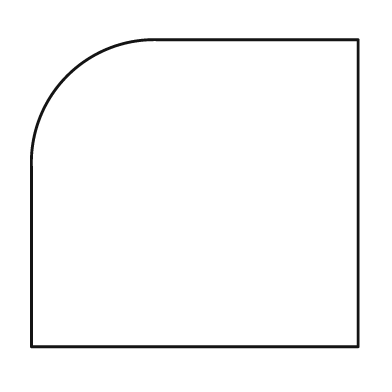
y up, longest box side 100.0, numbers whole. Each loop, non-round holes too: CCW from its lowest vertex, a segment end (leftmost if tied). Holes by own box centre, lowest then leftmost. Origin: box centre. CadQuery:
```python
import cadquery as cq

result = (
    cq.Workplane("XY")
    .moveTo(-50.0, -47.0)
    .lineTo(50.0, -47.0)
    .lineTo(50.0, 47.0)
    .lineTo(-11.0, 47.0)
    .threePointArc((-39.0, 36.0), (-50.0, 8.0))
    .close()
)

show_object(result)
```